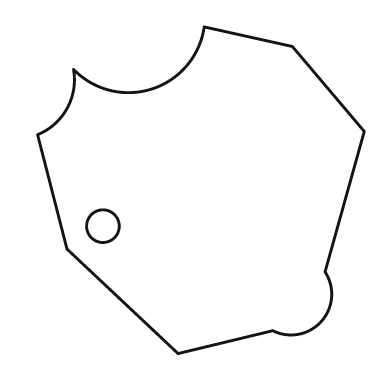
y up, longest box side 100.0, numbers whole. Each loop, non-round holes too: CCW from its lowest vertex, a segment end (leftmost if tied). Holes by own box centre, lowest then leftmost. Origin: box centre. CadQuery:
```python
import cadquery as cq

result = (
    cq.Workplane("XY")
    .moveTo(-7.0, -50.0)
    .lineTo(22.0, -43.0)
    .threePointArc((37.0, -40.0), (38.0, -25.0))
    .lineTo(50.0, 18.0)
    .lineTo(28.0, 44.0)
    .lineTo(1.0, 50.0)
    .threePointArc((-15.0, 31.0), (-39.0, 37.0))
    .threePointArc((-41.0, 25.0), (-50.0, 17.0))
    .lineTo(-41.0, -18.0)
    .close()
    .moveTo(-30.0, -11.0)
    .circle(5.0)
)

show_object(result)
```